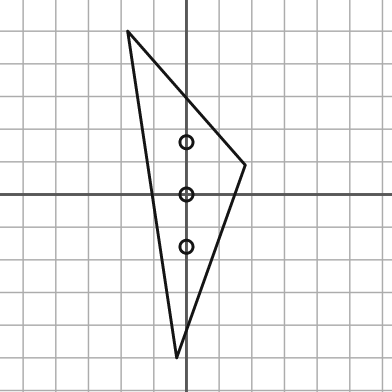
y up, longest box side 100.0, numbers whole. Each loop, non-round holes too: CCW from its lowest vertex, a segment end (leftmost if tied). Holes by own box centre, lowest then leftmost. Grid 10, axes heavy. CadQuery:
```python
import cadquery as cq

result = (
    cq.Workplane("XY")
    .moveTo(-3.0, -50.0)
    .lineTo(18.0, 9.0)
    .lineTo(-18.0, 50.0)
    .close()
    .moveTo(0.0, -16.0)
    .circle(2.0)
    .moveTo(0.0, 0.0)
    .circle(2.0)
    .moveTo(0.0, 16.0)
    .circle(2.0)
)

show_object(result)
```